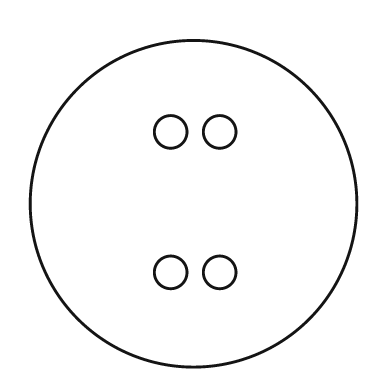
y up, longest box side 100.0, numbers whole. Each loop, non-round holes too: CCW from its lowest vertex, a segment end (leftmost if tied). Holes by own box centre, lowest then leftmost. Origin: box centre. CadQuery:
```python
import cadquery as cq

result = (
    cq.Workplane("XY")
    .moveTo(0.0, 0.0)
    .circle(50.0)
    .moveTo(-7.0, -21.0)
    .circle(5.0)
    .moveTo(8.0, -21.0)
    .circle(5.0)
    .moveTo(-7.0, 22.0)
    .circle(5.0)
    .moveTo(8.0, 22.0)
    .circle(5.0)
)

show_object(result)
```